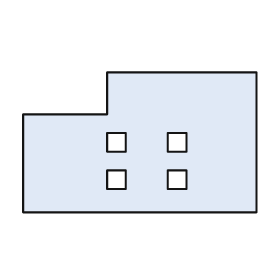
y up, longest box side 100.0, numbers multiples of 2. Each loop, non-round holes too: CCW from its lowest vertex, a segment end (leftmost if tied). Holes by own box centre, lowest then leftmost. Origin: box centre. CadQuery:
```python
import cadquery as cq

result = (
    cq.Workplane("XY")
    .moveTo(-50.0, -30.0)
    .lineTo(50.0, -30.0)
    .lineTo(50.0, 30.0)
    .lineTo(-14.0, 30.0)
    .lineTo(-14.0, 12.0)
    .lineTo(-50.0, 12.0)
    .close()
    .moveTo(-14.0, -20.0)
    .lineTo(-6.0, -20.0)
    .lineTo(-6.0, -12.0)
    .lineTo(-14.0, -12.0)
    .close()
    .moveTo(12.0, -20.0)
    .lineTo(20.0, -20.0)
    .lineTo(20.0, -12.0)
    .lineTo(12.0, -12.0)
    .close()
    .moveTo(-14.0, -4.0)
    .lineTo(-6.0, -4.0)
    .lineTo(-6.0, 4.0)
    .lineTo(-14.0, 4.0)
    .close()
    .moveTo(12.0, -4.0)
    .lineTo(20.0, -4.0)
    .lineTo(20.0, 4.0)
    .lineTo(12.0, 4.0)
    .close()
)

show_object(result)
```